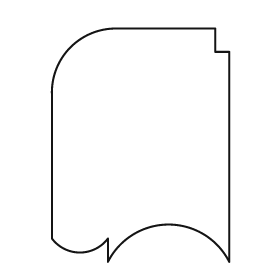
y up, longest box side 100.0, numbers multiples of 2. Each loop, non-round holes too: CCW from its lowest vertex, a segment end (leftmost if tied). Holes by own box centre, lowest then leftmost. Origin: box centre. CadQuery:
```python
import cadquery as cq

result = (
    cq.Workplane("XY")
    .moveTo(-14.0, -50.0)
    .threePointArc((12.0, -34.0), (38.0, -50.0))
    .lineTo(38.0, 40.0)
    .lineTo(32.0, 40.0)
    .lineTo(32.0, 50.0)
    .lineTo(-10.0, 50.0)
    .threePointArc((-30.0, 42.0), (-38.0, 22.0))
    .lineTo(-38.0, -40.0)
    .threePointArc((-26.0, -46.0), (-14.0, -40.0))
    .close()
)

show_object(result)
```